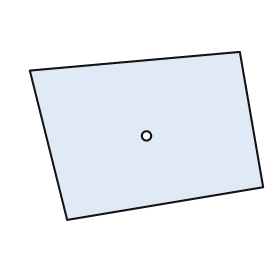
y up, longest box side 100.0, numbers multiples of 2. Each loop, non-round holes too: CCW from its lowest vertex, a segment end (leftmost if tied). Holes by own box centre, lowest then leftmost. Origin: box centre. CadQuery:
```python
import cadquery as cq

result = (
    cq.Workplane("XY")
    .moveTo(-34.0, -36.0)
    .lineTo(50.0, -22.0)
    .lineTo(40.0, 36.0)
    .lineTo(-50.0, 28.0)
    .close()
    .moveTo(0.0, 0.0)
    .circle(2.0)
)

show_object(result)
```